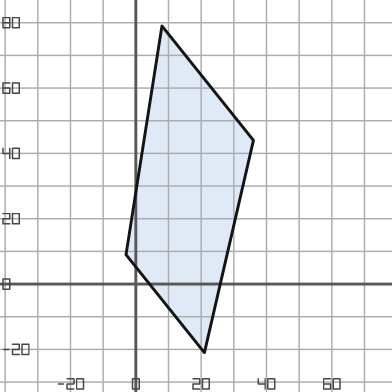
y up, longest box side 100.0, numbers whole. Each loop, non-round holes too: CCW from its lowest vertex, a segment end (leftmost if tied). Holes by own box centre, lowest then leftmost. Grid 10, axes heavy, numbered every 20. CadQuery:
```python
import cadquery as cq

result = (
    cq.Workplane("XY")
    .moveTo(21.0, -21.0)
    .lineTo(36.0, 44.0)
    .lineTo(8.0, 79.0)
    .lineTo(-3.0, 9.0)
    .close()
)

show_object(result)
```